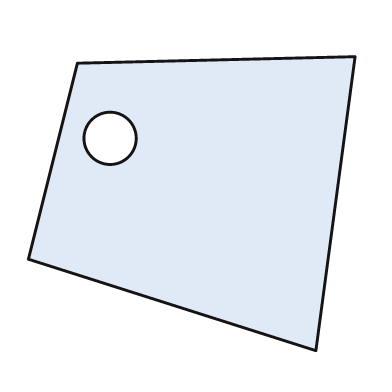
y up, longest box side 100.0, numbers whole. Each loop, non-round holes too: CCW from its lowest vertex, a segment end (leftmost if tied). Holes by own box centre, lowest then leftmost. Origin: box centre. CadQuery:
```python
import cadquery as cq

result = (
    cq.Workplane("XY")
    .moveTo(38.0, -45.0)
    .lineTo(50.0, 45.0)
    .lineTo(-35.0, 43.0)
    .lineTo(-50.0, -17.0)
    .close()
    .moveTo(-25.0, 20.0)
    .circle(8.0)
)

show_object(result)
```